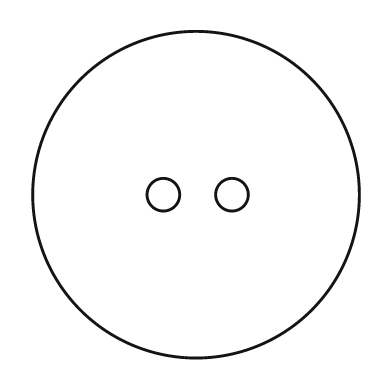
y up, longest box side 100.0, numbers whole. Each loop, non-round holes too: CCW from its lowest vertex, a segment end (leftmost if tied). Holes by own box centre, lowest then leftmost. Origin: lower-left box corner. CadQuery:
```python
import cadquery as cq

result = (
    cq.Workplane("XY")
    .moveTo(50.0, 50.0)
    .circle(50.0)
    .moveTo(40.0, 50.0)
    .circle(5.0)
    .moveTo(61.0, 50.0)
    .circle(5.0)
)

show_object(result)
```